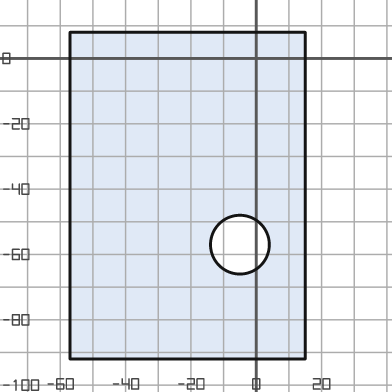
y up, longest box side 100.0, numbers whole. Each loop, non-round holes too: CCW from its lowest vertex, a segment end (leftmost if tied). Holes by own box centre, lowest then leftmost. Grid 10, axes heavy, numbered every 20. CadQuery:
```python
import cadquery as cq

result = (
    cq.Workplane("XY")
    .moveTo(-57.0, -92.0)
    .lineTo(15.0, -92.0)
    .lineTo(15.0, 8.0)
    .lineTo(-57.0, 8.0)
    .close()
    .moveTo(-5.0, -57.0)
    .circle(9.0)
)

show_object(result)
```